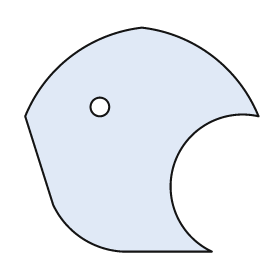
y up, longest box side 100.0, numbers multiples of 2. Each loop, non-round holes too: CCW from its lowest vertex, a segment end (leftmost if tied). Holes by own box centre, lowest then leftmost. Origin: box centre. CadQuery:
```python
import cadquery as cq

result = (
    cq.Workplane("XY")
    .moveTo(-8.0, -48.0)
    .lineTo(30.0, -48.0)
    .threePointArc((14.0, -10.0), (50.0, 10.0))
    .threePointArc((30.0, 36.0), (0.0, 48.0))
    .threePointArc((-30.0, 36.0), (-50.0, 10.0))
    .lineTo(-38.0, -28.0)
    .threePointArc((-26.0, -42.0), (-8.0, -48.0))
    .close()
    .moveTo(-18.0, 14.0)
    .circle(4.0)
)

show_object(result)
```